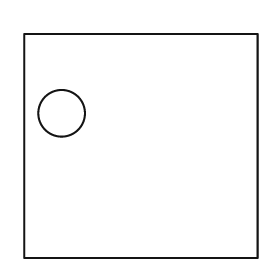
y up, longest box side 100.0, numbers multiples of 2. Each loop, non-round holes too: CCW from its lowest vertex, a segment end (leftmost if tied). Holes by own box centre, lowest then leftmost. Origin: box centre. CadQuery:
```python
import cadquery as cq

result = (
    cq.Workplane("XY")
    .moveTo(-50.0, -48.0)
    .lineTo(50.0, -48.0)
    .lineTo(50.0, 48.0)
    .lineTo(-50.0, 48.0)
    .close()
    .moveTo(-34.0, 14.0)
    .circle(10.0)
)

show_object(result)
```